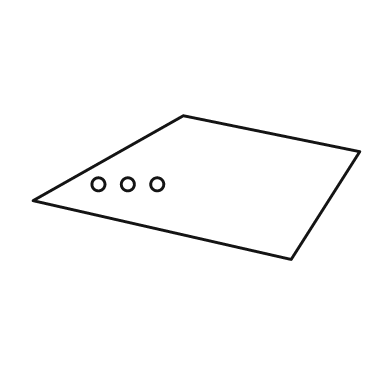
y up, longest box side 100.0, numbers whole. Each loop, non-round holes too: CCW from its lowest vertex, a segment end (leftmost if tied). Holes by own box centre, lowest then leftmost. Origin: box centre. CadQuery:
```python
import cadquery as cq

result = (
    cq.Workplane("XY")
    .moveTo(29.0, -22.0)
    .lineTo(50.0, 11.0)
    .lineTo(-4.0, 22.0)
    .lineTo(-50.0, -4.0)
    .close()
    .moveTo(-30.0, 1.0)
    .circle(2.0)
    .moveTo(-21.0, 1.0)
    .circle(2.0)
    .moveTo(-12.0, 1.0)
    .circle(2.0)
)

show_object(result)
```